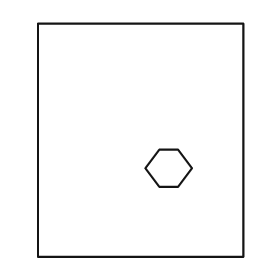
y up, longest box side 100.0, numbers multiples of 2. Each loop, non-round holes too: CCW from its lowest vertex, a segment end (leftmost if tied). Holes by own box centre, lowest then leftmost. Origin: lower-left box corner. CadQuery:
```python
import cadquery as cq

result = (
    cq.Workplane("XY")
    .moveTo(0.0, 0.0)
    .lineTo(88.0, 0.0)
    .lineTo(88.0, 100.0)
    .lineTo(0.0, 100.0)
    .close()
    .moveTo(52.0, 30.0)
    .lineTo(60.0, 30.0)
    .lineTo(66.0, 38.0)
    .lineTo(60.0, 46.0)
    .lineTo(52.0, 46.0)
    .lineTo(46.0, 38.0)
    .close()
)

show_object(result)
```